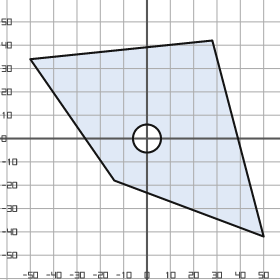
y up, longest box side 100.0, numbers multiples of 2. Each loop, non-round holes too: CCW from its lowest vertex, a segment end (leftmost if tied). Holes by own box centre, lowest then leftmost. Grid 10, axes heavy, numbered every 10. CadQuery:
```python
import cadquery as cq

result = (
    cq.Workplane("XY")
    .moveTo(50.0, -42.0)
    .lineTo(28.0, 42.0)
    .lineTo(-50.0, 34.0)
    .lineTo(-14.0, -18.0)
    .close()
    .moveTo(0.0, 0.0)
    .circle(6.0)
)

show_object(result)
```